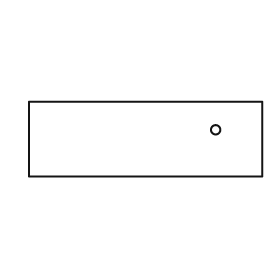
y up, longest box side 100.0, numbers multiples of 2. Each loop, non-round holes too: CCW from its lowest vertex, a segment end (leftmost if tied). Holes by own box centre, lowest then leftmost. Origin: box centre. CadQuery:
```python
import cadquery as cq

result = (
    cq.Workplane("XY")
    .moveTo(-50.0, -16.0)
    .lineTo(50.0, -16.0)
    .lineTo(50.0, 16.0)
    .lineTo(-50.0, 16.0)
    .close()
    .moveTo(30.0, 4.0)
    .circle(2.0)
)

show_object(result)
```